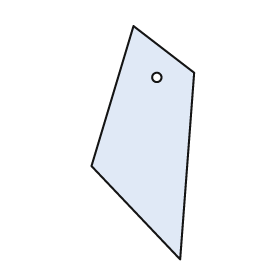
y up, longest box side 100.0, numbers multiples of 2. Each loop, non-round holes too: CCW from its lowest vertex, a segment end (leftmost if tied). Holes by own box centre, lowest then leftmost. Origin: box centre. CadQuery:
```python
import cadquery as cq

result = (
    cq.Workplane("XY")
    .moveTo(16.0, -50.0)
    .lineTo(22.0, 30.0)
    .lineTo(-4.0, 50.0)
    .lineTo(-22.0, -10.0)
    .close()
    .moveTo(6.0, 28.0)
    .circle(2.0)
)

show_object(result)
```